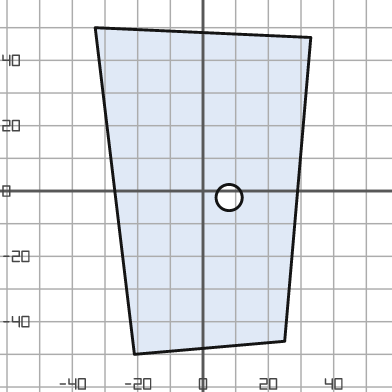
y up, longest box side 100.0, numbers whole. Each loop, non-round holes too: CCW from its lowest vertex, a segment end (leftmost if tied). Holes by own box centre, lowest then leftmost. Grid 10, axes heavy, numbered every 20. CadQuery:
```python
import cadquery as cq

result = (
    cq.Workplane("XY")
    .moveTo(-21.0, -50.0)
    .lineTo(25.0, -46.0)
    .lineTo(33.0, 47.0)
    .lineTo(-33.0, 50.0)
    .close()
    .moveTo(8.0, -2.0)
    .circle(4.0)
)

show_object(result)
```